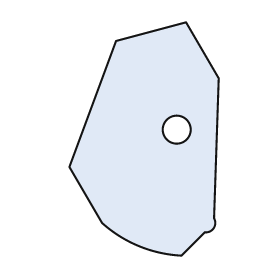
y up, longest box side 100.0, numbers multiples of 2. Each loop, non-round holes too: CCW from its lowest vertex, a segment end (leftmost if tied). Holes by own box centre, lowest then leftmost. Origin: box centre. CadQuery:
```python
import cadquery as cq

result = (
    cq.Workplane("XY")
    .moveTo(16.0, -50.0)
    .lineTo(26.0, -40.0)
    .threePointArc((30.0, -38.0), (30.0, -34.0))
    .lineTo(32.0, 26.0)
    .lineTo(18.0, 50.0)
    .lineTo(-12.0, 42.0)
    .lineTo(-32.0, -12.0)
    .lineTo(-18.0, -36.0)
    .threePointArc((-2.0, -46.0), (16.0, -50.0))
    .close()
    .moveTo(14.0, 4.0)
    .circle(6.0)
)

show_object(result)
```